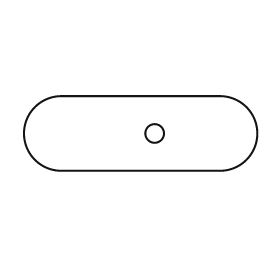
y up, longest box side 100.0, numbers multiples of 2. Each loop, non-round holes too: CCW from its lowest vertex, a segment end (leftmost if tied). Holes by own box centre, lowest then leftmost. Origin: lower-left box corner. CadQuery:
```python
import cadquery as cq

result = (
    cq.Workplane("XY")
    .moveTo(16.0, 0.0)
    .lineTo(84.0, 0.0)
    .threePointArc((100.0, 16.0), (84.0, 32.0))
    .lineTo(16.0, 32.0)
    .threePointArc((0.0, 16.0), (16.0, 0.0))
    .close()
    .moveTo(56.0, 16.0)
    .circle(4.0)
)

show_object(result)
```